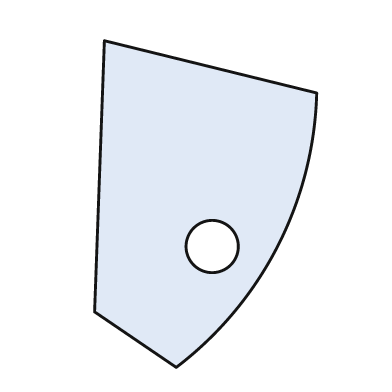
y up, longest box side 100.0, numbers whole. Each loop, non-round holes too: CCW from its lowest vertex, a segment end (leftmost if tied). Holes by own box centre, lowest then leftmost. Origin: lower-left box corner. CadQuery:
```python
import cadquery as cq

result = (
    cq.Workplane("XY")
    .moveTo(25.0, 0.0)
    .threePointArc((56.0, 37.0), (68.0, 84.0))
    .lineTo(3.0, 100.0)
    .lineTo(0.0, 17.0)
    .close()
    .moveTo(36.0, 37.0)
    .circle(8.0)
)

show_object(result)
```